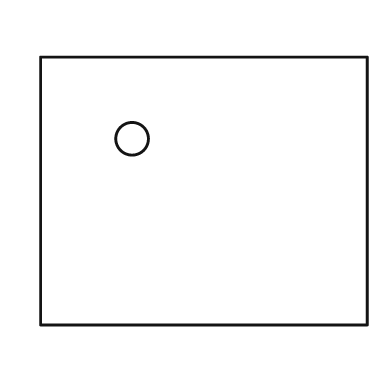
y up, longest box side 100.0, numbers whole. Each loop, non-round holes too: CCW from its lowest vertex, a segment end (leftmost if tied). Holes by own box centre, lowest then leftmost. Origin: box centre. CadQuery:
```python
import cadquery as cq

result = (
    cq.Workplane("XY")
    .moveTo(-50.0, -41.0)
    .lineTo(50.0, -41.0)
    .lineTo(50.0, 41.0)
    .lineTo(-50.0, 41.0)
    .close()
    .moveTo(-22.0, 16.0)
    .circle(5.0)
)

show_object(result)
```